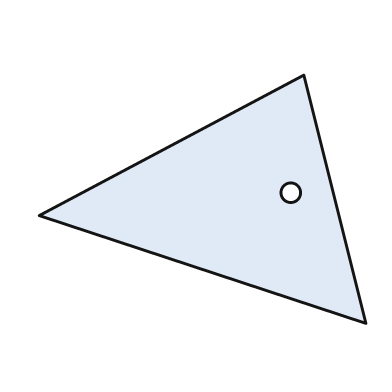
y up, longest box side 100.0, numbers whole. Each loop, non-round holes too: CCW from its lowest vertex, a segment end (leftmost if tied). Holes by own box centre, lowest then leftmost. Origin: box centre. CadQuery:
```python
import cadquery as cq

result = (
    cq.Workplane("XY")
    .moveTo(50.0, -38.0)
    .lineTo(31.0, 38.0)
    .lineTo(-50.0, -5.0)
    .close()
    .moveTo(27.0, 2.0)
    .circle(3.0)
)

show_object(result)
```